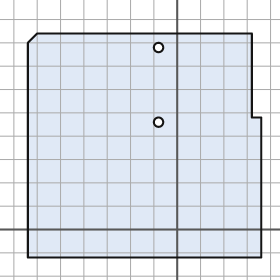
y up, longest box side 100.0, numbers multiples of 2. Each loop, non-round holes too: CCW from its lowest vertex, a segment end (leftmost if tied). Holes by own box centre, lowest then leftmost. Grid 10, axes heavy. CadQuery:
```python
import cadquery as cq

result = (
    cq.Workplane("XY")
    .moveTo(-64.0, -12.0)
    .lineTo(36.0, -12.0)
    .lineTo(36.0, 48.0)
    .lineTo(32.0, 48.0)
    .lineTo(32.0, 84.0)
    .lineTo(-60.0, 84.0)
    .lineTo(-64.0, 80.0)
    .close()
    .moveTo(-8.0, 46.0)
    .circle(2.0)
    .moveTo(-8.0, 78.0)
    .circle(2.0)
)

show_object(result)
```